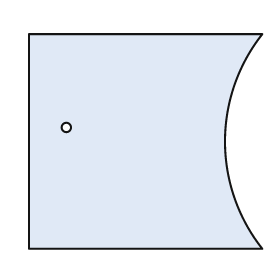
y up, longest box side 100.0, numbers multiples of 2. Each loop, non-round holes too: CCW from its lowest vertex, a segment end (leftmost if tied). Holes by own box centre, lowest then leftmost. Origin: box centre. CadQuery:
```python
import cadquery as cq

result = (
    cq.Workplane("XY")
    .moveTo(-50.0, -46.0)
    .lineTo(50.0, -46.0)
    .threePointArc((34.0, 0.0), (50.0, 46.0))
    .lineTo(-50.0, 46.0)
    .close()
    .moveTo(-34.0, 6.0)
    .circle(2.0)
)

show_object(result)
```